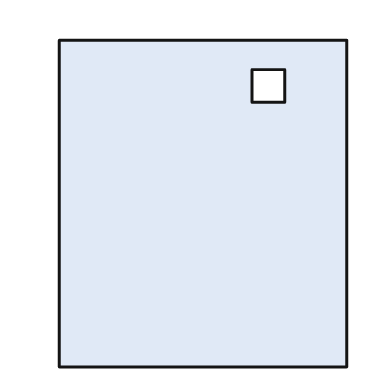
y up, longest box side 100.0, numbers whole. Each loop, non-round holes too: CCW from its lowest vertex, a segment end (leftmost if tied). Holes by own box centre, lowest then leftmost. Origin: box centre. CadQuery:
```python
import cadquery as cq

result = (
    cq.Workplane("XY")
    .moveTo(-44.0, -50.0)
    .lineTo(44.0, -50.0)
    .lineTo(44.0, 50.0)
    .lineTo(-44.0, 50.0)
    .close()
    .moveTo(15.0, 31.0)
    .lineTo(25.0, 31.0)
    .lineTo(25.0, 41.0)
    .lineTo(15.0, 41.0)
    .close()
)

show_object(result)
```